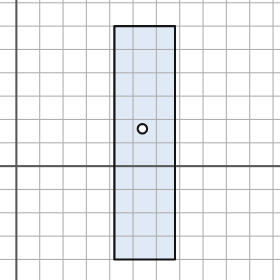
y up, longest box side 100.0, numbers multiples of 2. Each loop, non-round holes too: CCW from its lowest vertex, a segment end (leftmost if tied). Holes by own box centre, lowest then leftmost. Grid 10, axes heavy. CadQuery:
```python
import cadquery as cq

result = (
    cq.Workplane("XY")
    .moveTo(42.0, -40.0)
    .lineTo(68.0, -40.0)
    .lineTo(68.0, 60.0)
    .lineTo(42.0, 60.0)
    .close()
    .moveTo(54.0, 16.0)
    .circle(2.0)
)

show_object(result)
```